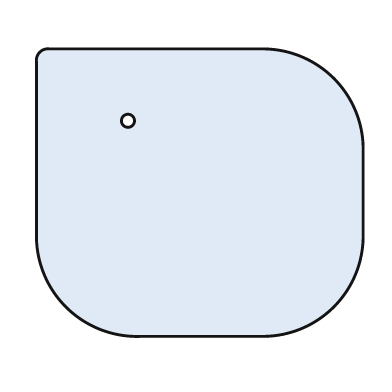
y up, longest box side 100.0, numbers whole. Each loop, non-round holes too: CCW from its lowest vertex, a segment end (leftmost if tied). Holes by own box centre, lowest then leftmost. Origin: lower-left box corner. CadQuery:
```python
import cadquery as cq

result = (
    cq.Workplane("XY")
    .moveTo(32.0, 0.0)
    .lineTo(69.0, 0.0)
    .threePointArc((91.0, 9.0), (100.0, 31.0))
    .lineTo(100.0, 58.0)
    .threePointArc((91.0, 79.0), (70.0, 88.0))
    .lineTo(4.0, 88.0)
    .threePointArc((1.0, 87.0), (0.0, 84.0))
    .lineTo(0.0, 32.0)
    .threePointArc((9.0, 9.0), (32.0, 0.0))
    .close()
    .moveTo(28.0, 66.0)
    .circle(2.0)
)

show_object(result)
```